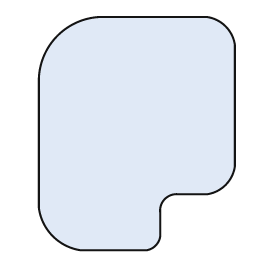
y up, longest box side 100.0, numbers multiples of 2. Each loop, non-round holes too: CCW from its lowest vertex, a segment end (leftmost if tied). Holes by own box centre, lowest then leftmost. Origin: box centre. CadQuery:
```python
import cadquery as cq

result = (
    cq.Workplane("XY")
    .moveTo(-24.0, -50.0)
    .lineTo(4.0, -50.0)
    .threePointArc((8.0, -48.0), (10.0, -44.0))
    .lineTo(10.0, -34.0)
    .threePointArc((12.0, -28.0), (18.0, -26.0))
    .lineTo(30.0, -26.0)
    .threePointArc((38.0, -22.0), (42.0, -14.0))
    .lineTo(42.0, 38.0)
    .threePointArc((38.0, 46.0), (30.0, 50.0))
    .lineTo(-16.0, 50.0)
    .threePointArc((-34.0, 42.0), (-42.0, 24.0))
    .lineTo(-42.0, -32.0)
    .threePointArc((-36.0, -44.0), (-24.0, -50.0))
    .close()
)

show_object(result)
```